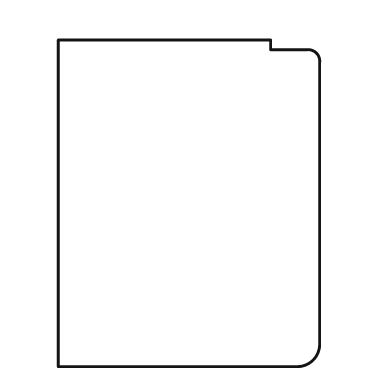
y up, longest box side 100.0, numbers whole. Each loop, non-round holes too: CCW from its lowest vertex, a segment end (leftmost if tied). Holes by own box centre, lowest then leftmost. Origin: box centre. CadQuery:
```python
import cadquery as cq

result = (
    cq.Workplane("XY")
    .moveTo(-40.0, -50.0)
    .lineTo(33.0, -50.0)
    .threePointArc((38.0, -48.0), (40.0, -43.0))
    .lineTo(40.0, 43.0)
    .threePointArc((39.0, 46.0), (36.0, 47.0))
    .lineTo(25.0, 47.0)
    .lineTo(25.0, 50.0)
    .lineTo(-40.0, 50.0)
    .close()
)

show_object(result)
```